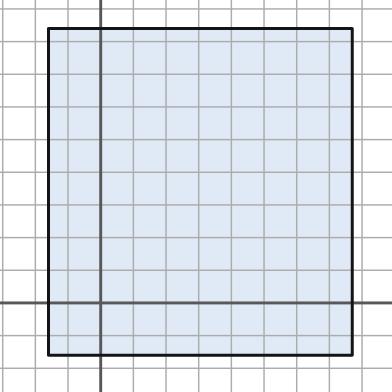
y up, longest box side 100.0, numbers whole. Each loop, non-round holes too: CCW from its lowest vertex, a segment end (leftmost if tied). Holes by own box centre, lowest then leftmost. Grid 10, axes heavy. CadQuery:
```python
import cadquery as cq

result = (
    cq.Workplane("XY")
    .moveTo(-16.0, -16.0)
    .lineTo(77.0, -16.0)
    .lineTo(77.0, 84.0)
    .lineTo(-16.0, 84.0)
    .close()
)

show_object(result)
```